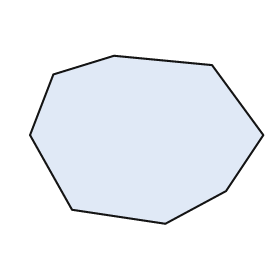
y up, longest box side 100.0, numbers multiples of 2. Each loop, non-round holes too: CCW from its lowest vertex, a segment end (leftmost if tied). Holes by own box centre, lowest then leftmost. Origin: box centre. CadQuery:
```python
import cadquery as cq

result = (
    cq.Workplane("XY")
    .moveTo(8.0, -36.0)
    .lineTo(34.0, -22.0)
    .lineTo(50.0, 2.0)
    .lineTo(28.0, 32.0)
    .lineTo(-14.0, 36.0)
    .lineTo(-40.0, 28.0)
    .lineTo(-50.0, 2.0)
    .lineTo(-32.0, -30.0)
    .close()
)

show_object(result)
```